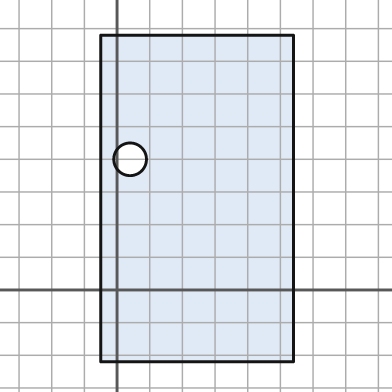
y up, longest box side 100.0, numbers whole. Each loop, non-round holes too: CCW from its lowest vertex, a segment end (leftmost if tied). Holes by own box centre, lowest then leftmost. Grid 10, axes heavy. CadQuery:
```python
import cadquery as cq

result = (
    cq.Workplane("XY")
    .moveTo(-5.0, -22.0)
    .lineTo(54.0, -22.0)
    .lineTo(54.0, 78.0)
    .lineTo(-5.0, 78.0)
    .close()
    .moveTo(4.0, 40.0)
    .circle(5.0)
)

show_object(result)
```